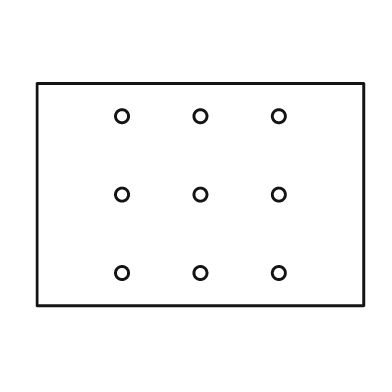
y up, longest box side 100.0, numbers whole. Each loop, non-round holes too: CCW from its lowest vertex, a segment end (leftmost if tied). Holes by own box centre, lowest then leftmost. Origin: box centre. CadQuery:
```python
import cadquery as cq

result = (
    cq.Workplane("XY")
    .moveTo(-50.0, -34.0)
    .lineTo(50.0, -34.0)
    .lineTo(50.0, 34.0)
    .lineTo(-50.0, 34.0)
    .close()
    .moveTo(-24.0, -24.0)
    .circle(2.0)
    .moveTo(0.0, -24.0)
    .circle(2.0)
    .moveTo(24.0, -24.0)
    .circle(2.0)
    .moveTo(-24.0, 0.0)
    .circle(2.0)
    .moveTo(0.0, 0.0)
    .circle(2.0)
    .moveTo(24.0, 0.0)
    .circle(2.0)
    .moveTo(-24.0, 24.0)
    .circle(2.0)
    .moveTo(0.0, 24.0)
    .circle(2.0)
    .moveTo(24.0, 24.0)
    .circle(2.0)
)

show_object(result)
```